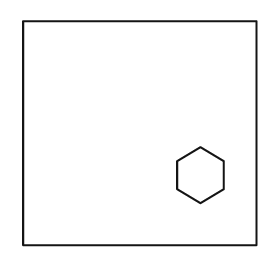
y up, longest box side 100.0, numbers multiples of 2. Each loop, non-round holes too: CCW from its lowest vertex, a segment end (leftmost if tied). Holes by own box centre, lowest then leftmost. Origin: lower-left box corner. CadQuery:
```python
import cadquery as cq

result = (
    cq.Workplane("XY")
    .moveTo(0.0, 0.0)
    .lineTo(100.0, 0.0)
    .lineTo(100.0, 96.0)
    .lineTo(0.0, 96.0)
    .close()
    .moveTo(76.0, 18.0)
    .lineTo(86.0, 24.0)
    .lineTo(86.0, 36.0)
    .lineTo(76.0, 42.0)
    .lineTo(66.0, 36.0)
    .lineTo(66.0, 24.0)
    .close()
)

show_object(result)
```